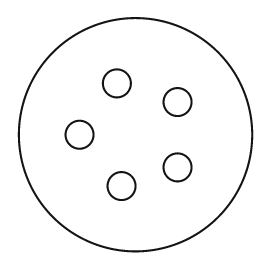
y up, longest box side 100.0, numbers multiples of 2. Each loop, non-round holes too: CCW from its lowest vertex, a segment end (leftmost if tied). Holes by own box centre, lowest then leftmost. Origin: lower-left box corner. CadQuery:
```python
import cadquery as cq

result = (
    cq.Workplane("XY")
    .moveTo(50.0, 50.0)
    .circle(50.0)
    .moveTo(44.0, 28.0)
    .circle(6.0)
    .moveTo(68.0, 36.0)
    .circle(6.0)
    .moveTo(26.0, 50.0)
    .circle(6.0)
    .moveTo(68.0, 64.0)
    .circle(6.0)
    .moveTo(42.0, 72.0)
    .circle(6.0)
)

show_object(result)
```